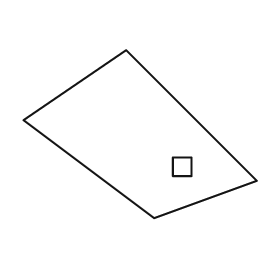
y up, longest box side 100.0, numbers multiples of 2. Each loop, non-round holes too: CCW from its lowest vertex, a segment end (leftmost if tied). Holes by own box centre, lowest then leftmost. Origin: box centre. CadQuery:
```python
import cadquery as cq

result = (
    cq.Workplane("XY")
    .moveTo(6.0, -36.0)
    .lineTo(50.0, -20.0)
    .lineTo(-6.0, 36.0)
    .lineTo(-50.0, 6.0)
    .close()
    .moveTo(14.0, -18.0)
    .lineTo(22.0, -18.0)
    .lineTo(22.0, -10.0)
    .lineTo(14.0, -10.0)
    .close()
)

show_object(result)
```